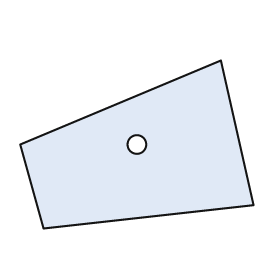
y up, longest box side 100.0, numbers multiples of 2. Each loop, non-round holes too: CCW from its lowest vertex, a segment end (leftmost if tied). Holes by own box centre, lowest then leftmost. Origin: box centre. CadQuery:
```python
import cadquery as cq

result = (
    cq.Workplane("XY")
    .moveTo(-40.0, -36.0)
    .lineTo(50.0, -26.0)
    .lineTo(36.0, 36.0)
    .lineTo(-50.0, 0.0)
    .close()
    .moveTo(0.0, 0.0)
    .circle(4.0)
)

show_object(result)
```